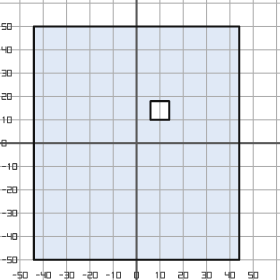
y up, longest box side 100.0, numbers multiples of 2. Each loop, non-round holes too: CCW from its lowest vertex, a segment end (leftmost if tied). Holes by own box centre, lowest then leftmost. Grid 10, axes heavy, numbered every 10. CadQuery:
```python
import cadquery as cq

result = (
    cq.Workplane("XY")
    .moveTo(-44.0, -50.0)
    .lineTo(44.0, -50.0)
    .lineTo(44.0, 50.0)
    .lineTo(-44.0, 50.0)
    .close()
    .moveTo(6.0, 10.0)
    .lineTo(14.0, 10.0)
    .lineTo(14.0, 18.0)
    .lineTo(6.0, 18.0)
    .close()
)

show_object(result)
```